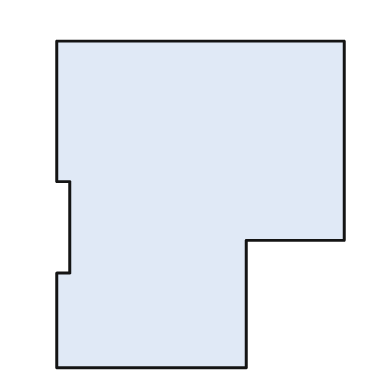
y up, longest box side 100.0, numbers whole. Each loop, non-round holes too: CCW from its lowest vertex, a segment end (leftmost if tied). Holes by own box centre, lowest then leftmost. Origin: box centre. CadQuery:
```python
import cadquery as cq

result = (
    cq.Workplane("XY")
    .moveTo(-44.0, -50.0)
    .lineTo(14.0, -50.0)
    .lineTo(14.0, -11.0)
    .lineTo(44.0, -11.0)
    .lineTo(44.0, 50.0)
    .lineTo(-44.0, 50.0)
    .lineTo(-44.0, 7.0)
    .lineTo(-40.0, 7.0)
    .lineTo(-40.0, -21.0)
    .lineTo(-44.0, -21.0)
    .close()
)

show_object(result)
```